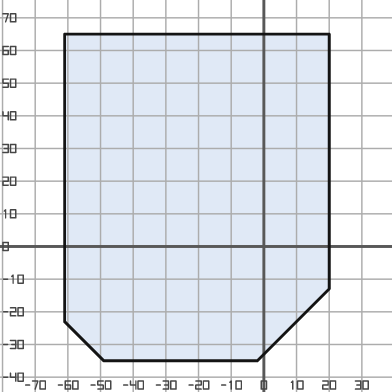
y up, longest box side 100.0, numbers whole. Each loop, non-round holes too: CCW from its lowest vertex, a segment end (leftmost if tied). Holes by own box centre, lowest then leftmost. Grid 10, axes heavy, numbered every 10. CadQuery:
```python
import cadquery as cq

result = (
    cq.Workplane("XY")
    .moveTo(-49.0, -35.0)
    .lineTo(-2.0, -35.0)
    .lineTo(20.0, -13.0)
    .lineTo(20.0, 65.0)
    .lineTo(-61.0, 65.0)
    .lineTo(-61.0, -23.0)
    .close()
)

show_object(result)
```